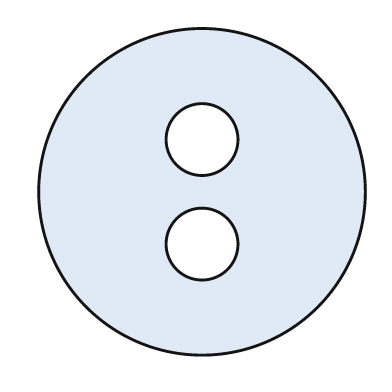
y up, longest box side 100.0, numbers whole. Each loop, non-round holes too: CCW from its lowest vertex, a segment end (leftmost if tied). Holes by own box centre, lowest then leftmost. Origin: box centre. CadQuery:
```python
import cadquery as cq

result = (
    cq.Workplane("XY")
    .moveTo(0.0, 0.0)
    .circle(50.0)
    .moveTo(0.0, -16.0)
    .circle(11.0)
    .moveTo(0.0, 16.0)
    .circle(11.0)
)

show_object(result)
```